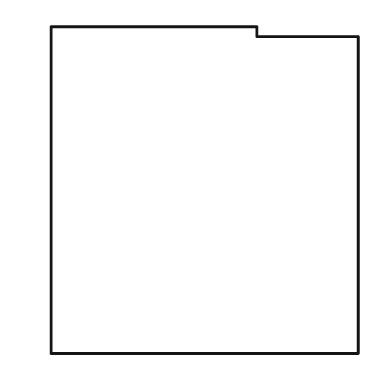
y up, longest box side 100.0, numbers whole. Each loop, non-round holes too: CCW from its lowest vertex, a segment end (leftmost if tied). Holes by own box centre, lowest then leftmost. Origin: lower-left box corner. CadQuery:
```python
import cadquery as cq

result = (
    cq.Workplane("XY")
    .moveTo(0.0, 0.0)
    .lineTo(94.0, 0.0)
    .lineTo(94.0, 97.0)
    .lineTo(63.0, 97.0)
    .lineTo(63.0, 100.0)
    .lineTo(0.0, 100.0)
    .close()
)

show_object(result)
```